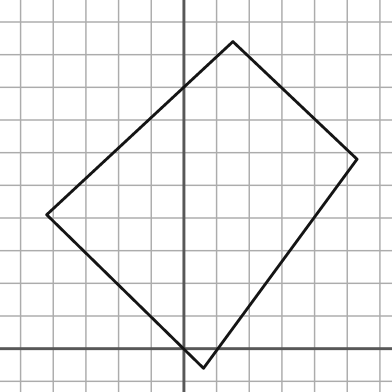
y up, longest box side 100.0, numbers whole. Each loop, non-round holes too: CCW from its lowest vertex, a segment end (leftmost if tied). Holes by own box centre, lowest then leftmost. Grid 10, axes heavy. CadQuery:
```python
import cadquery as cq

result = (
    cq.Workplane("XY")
    .moveTo(6.0, -6.0)
    .lineTo(53.0, 58.0)
    .lineTo(15.0, 94.0)
    .lineTo(-42.0, 41.0)
    .close()
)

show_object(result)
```